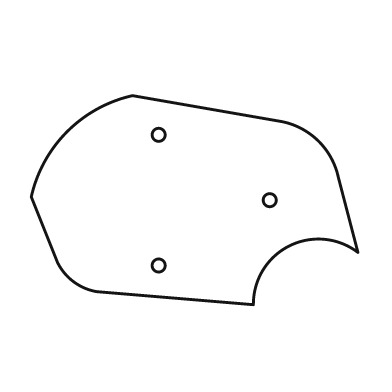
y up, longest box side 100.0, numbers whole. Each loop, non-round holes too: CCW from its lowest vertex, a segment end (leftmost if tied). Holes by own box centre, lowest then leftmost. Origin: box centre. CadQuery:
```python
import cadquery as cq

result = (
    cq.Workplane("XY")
    .moveTo(18.0, -32.0)
    .threePointArc((29.0, -14.0), (50.0, -16.0))
    .lineTo(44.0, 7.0)
    .threePointArc((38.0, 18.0), (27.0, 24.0))
    .lineTo(-19.0, 32.0)
    .threePointArc((-39.0, 21.0), (-50.0, 1.0))
    .lineTo(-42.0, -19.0)
    .threePointArc((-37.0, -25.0), (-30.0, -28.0))
    .close()
    .moveTo(-11.0, -20.0)
    .circle(2.0)
    .moveTo(23.0, 0.0)
    .circle(2.0)
    .moveTo(-11.0, 20.0)
    .circle(2.0)
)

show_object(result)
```